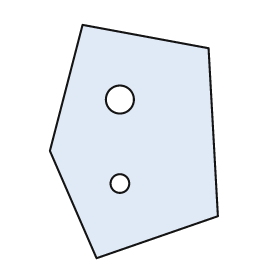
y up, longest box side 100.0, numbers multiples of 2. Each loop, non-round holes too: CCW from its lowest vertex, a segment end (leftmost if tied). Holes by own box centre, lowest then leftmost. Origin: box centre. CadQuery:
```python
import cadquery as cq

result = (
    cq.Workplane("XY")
    .moveTo(-16.0, -50.0)
    .lineTo(36.0, -32.0)
    .lineTo(32.0, 40.0)
    .lineTo(-22.0, 50.0)
    .lineTo(-36.0, -4.0)
    .close()
    .moveTo(-6.0, -18.0)
    .circle(4.0)
    .moveTo(-6.0, 18.0)
    .circle(6.0)
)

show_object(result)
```